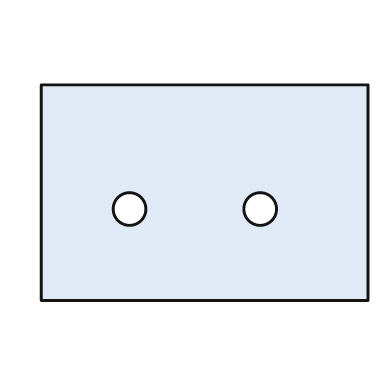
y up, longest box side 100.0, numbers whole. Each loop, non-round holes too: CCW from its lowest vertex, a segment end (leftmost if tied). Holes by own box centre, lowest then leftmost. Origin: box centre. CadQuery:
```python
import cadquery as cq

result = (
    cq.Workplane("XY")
    .moveTo(-50.0, -33.0)
    .lineTo(50.0, -33.0)
    .lineTo(50.0, 33.0)
    .lineTo(-50.0, 33.0)
    .close()
    .moveTo(-23.0, -5.0)
    .circle(5.0)
    .moveTo(17.0, -5.0)
    .circle(5.0)
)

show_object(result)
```